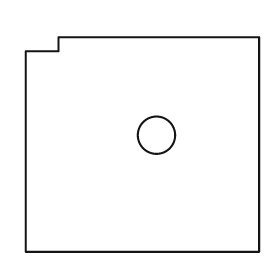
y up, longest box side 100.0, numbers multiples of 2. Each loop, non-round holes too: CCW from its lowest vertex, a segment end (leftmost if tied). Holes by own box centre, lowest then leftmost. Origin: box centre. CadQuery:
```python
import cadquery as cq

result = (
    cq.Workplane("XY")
    .moveTo(-50.0, -46.0)
    .lineTo(50.0, -46.0)
    .lineTo(50.0, 46.0)
    .lineTo(-36.0, 46.0)
    .lineTo(-36.0, 40.0)
    .lineTo(-50.0, 40.0)
    .close()
    .moveTo(6.0, 4.0)
    .circle(8.0)
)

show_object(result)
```